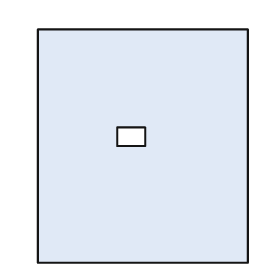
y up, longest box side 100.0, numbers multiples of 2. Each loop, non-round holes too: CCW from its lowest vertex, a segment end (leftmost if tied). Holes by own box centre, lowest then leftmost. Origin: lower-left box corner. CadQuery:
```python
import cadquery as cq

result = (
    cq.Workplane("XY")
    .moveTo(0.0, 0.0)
    .lineTo(90.0, 0.0)
    .lineTo(90.0, 100.0)
    .lineTo(0.0, 100.0)
    .close()
    .moveTo(34.0, 50.0)
    .lineTo(46.0, 50.0)
    .lineTo(46.0, 58.0)
    .lineTo(34.0, 58.0)
    .close()
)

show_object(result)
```